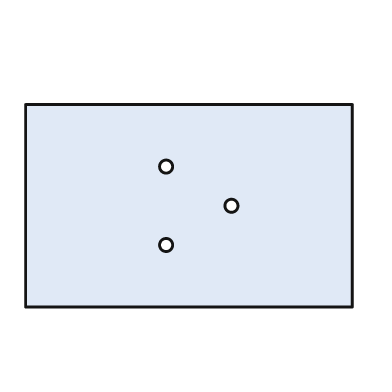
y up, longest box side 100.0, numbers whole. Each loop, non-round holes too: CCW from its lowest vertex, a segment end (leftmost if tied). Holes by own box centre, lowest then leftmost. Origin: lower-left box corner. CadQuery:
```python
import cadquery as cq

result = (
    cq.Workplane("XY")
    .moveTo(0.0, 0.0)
    .lineTo(100.0, 0.0)
    .lineTo(100.0, 62.0)
    .lineTo(0.0, 62.0)
    .close()
    .moveTo(43.0, 19.0)
    .circle(2.0)
    .moveTo(63.0, 31.0)
    .circle(2.0)
    .moveTo(43.0, 43.0)
    .circle(2.0)
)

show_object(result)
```